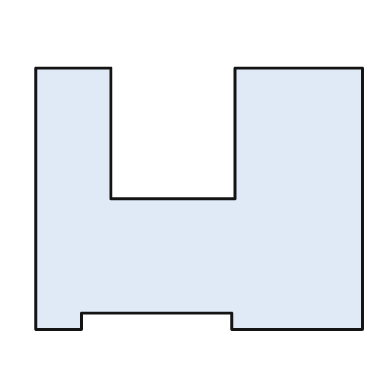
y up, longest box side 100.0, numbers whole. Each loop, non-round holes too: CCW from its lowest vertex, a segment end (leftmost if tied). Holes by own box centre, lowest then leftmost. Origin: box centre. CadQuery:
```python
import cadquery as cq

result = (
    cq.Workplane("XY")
    .moveTo(-50.0, -40.0)
    .lineTo(-36.0, -40.0)
    .lineTo(-36.0, -35.0)
    .lineTo(10.0, -35.0)
    .lineTo(10.0, -40.0)
    .lineTo(50.0, -40.0)
    .lineTo(50.0, 40.0)
    .lineTo(11.0, 40.0)
    .lineTo(11.0, 0.0)
    .lineTo(-27.0, 0.0)
    .lineTo(-27.0, 40.0)
    .lineTo(-50.0, 40.0)
    .close()
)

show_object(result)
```